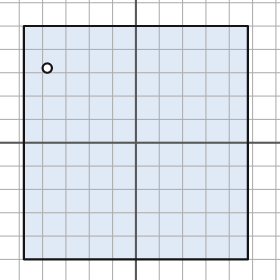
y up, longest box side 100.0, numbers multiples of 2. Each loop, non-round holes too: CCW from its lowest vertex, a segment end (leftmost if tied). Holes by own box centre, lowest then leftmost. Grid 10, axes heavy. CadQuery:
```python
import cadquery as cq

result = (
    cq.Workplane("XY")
    .moveTo(-48.0, -50.0)
    .lineTo(48.0, -50.0)
    .lineTo(48.0, 50.0)
    .lineTo(-48.0, 50.0)
    .close()
    .moveTo(-38.0, 32.0)
    .circle(2.0)
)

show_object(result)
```